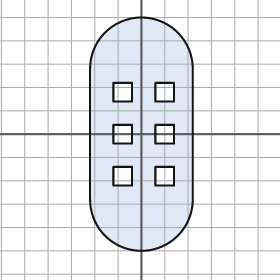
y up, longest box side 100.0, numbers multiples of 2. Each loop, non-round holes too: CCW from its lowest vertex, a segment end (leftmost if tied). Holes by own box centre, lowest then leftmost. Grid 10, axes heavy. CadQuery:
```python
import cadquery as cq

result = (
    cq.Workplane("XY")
    .moveTo(-22.0, -28.0)
    .threePointArc((0.0, -50.0), (22.0, -28.0))
    .lineTo(22.0, 28.0)
    .threePointArc((0.0, 50.0), (-22.0, 28.0))
    .close()
    .moveTo(-12.0, -22.0)
    .lineTo(-4.0, -22.0)
    .lineTo(-4.0, -14.0)
    .lineTo(-12.0, -14.0)
    .close()
    .moveTo(6.0, -22.0)
    .lineTo(14.0, -22.0)
    .lineTo(14.0, -14.0)
    .lineTo(6.0, -14.0)
    .close()
    .moveTo(-12.0, -4.0)
    .lineTo(-4.0, -4.0)
    .lineTo(-4.0, 4.0)
    .lineTo(-12.0, 4.0)
    .close()
    .moveTo(6.0, -4.0)
    .lineTo(14.0, -4.0)
    .lineTo(14.0, 4.0)
    .lineTo(6.0, 4.0)
    .close()
    .moveTo(-12.0, 14.0)
    .lineTo(-4.0, 14.0)
    .lineTo(-4.0, 22.0)
    .lineTo(-12.0, 22.0)
    .close()
    .moveTo(6.0, 14.0)
    .lineTo(14.0, 14.0)
    .lineTo(14.0, 22.0)
    .lineTo(6.0, 22.0)
    .close()
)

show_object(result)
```